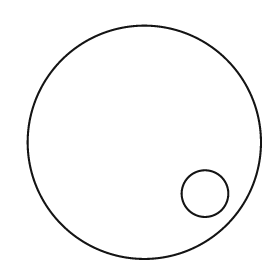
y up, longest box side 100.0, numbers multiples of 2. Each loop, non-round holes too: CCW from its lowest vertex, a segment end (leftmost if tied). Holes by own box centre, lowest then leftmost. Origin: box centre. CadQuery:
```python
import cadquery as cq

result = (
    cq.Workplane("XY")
    .moveTo(0.0, 0.0)
    .circle(50.0)
    .moveTo(26.0, -22.0)
    .circle(10.0)
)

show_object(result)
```